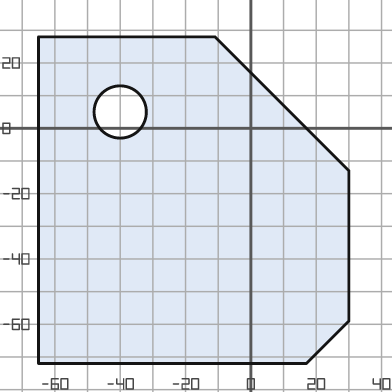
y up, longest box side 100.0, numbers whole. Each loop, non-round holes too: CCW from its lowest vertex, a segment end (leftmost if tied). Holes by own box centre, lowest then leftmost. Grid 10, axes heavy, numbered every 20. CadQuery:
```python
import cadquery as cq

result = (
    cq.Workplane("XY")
    .moveTo(-65.0, -72.0)
    .lineTo(17.0, -72.0)
    .lineTo(30.0, -59.0)
    .lineTo(30.0, -13.0)
    .lineTo(-11.0, 28.0)
    .lineTo(-65.0, 28.0)
    .close()
    .moveTo(-40.0, 5.0)
    .circle(8.0)
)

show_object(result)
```